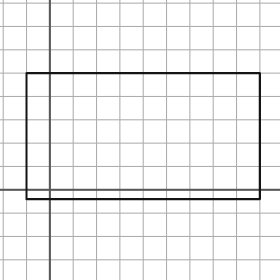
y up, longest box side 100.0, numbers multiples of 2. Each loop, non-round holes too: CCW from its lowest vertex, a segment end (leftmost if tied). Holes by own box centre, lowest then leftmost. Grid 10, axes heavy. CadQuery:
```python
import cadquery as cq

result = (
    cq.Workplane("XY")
    .moveTo(-10.0, -4.0)
    .lineTo(90.0, -4.0)
    .lineTo(90.0, 50.0)
    .lineTo(-10.0, 50.0)
    .close()
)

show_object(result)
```